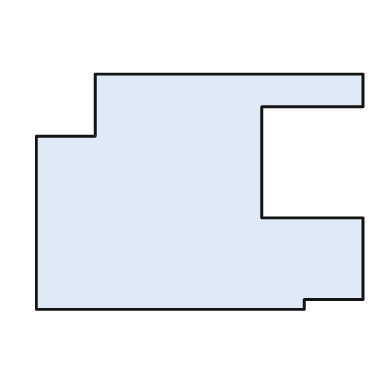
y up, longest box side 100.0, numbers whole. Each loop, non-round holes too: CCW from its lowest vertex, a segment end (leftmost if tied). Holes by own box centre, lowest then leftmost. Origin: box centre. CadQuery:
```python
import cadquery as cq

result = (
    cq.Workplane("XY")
    .moveTo(-50.0, -36.0)
    .lineTo(32.0, -36.0)
    .lineTo(32.0, -33.0)
    .lineTo(50.0, -33.0)
    .lineTo(50.0, -8.0)
    .lineTo(19.0, -8.0)
    .lineTo(19.0, 26.0)
    .lineTo(50.0, 26.0)
    .lineTo(50.0, 36.0)
    .lineTo(-32.0, 36.0)
    .lineTo(-32.0, 17.0)
    .lineTo(-50.0, 17.0)
    .close()
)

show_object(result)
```